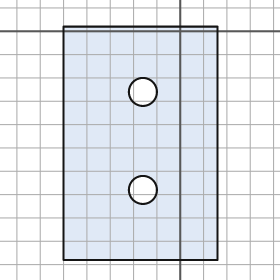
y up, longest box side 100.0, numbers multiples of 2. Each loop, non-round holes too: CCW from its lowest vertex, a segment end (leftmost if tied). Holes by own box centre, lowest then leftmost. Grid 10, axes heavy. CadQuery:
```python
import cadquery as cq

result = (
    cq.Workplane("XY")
    .moveTo(-50.0, -98.0)
    .lineTo(16.0, -98.0)
    .lineTo(16.0, 2.0)
    .lineTo(-50.0, 2.0)
    .close()
    .moveTo(-16.0, -68.0)
    .circle(6.0)
    .moveTo(-16.0, -26.0)
    .circle(6.0)
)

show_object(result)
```